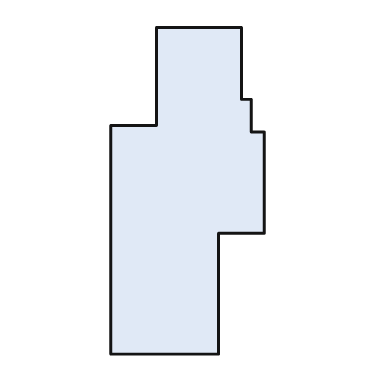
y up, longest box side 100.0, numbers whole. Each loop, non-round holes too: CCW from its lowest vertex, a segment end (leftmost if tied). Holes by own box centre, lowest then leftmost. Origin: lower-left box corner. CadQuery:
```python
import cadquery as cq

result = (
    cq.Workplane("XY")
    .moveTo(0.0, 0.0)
    .lineTo(33.0, 0.0)
    .lineTo(33.0, 37.0)
    .lineTo(47.0, 37.0)
    .lineTo(47.0, 68.0)
    .lineTo(43.0, 68.0)
    .lineTo(43.0, 78.0)
    .lineTo(40.0, 78.0)
    .lineTo(40.0, 100.0)
    .lineTo(14.0, 100.0)
    .lineTo(14.0, 70.0)
    .lineTo(0.0, 70.0)
    .close()
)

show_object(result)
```